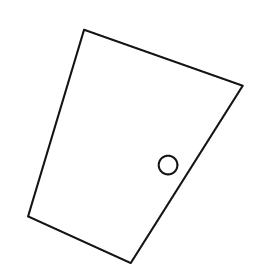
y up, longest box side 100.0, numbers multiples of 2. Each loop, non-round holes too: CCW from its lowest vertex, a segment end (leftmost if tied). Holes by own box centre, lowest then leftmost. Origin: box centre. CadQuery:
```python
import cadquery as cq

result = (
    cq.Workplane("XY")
    .moveTo(-2.0, -50.0)
    .lineTo(46.0, 26.0)
    .lineTo(-22.0, 50.0)
    .lineTo(-46.0, -30.0)
    .close()
    .moveTo(14.0, -8.0)
    .circle(4.0)
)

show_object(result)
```